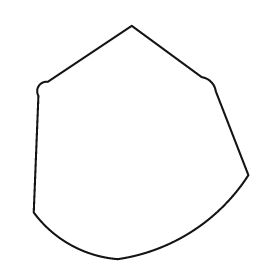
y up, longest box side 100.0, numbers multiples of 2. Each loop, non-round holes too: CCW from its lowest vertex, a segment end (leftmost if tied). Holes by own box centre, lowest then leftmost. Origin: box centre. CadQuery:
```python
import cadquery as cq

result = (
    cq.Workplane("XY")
    .moveTo(-10.0, -50.0)
    .threePointArc((22.0, -38.0), (46.0, -14.0))
    .lineTo(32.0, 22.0)
    .threePointArc((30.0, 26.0), (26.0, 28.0))
    .lineTo(-4.0, 50.0)
    .lineTo(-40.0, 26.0)
    .threePointArc((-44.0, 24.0), (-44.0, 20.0))
    .lineTo(-46.0, -30.0)
    .threePointArc((-30.0, -44.0), (-10.0, -50.0))
    .close()
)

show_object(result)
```